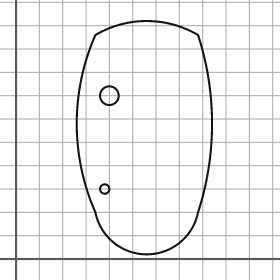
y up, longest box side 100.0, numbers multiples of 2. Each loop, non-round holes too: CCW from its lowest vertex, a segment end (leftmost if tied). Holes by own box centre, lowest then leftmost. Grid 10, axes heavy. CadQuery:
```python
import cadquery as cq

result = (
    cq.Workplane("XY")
    .moveTo(34.0, 20.0)
    .threePointArc((56.0, 2.0), (78.0, 20.0))
    .threePointArc((84.0, 58.0), (78.0, 96.0))
    .threePointArc((56.0, 102.0), (34.0, 96.0))
    .threePointArc((26.0, 58.0), (34.0, 20.0))
    .close()
    .moveTo(38.0, 30.0)
    .circle(2.0)
    .moveTo(40.0, 70.0)
    .circle(4.0)
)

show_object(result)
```